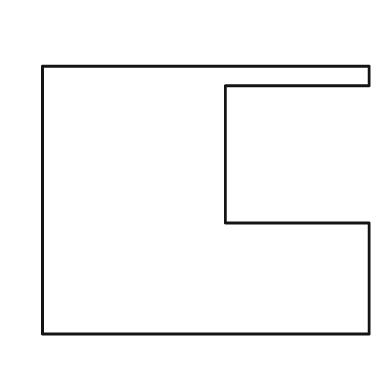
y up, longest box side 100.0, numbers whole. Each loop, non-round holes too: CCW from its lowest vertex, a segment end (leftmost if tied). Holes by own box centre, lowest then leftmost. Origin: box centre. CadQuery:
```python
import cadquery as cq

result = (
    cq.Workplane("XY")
    .moveTo(-50.0, -41.0)
    .lineTo(50.0, -41.0)
    .lineTo(50.0, -7.0)
    .lineTo(6.0, -7.0)
    .lineTo(6.0, 35.0)
    .lineTo(50.0, 35.0)
    .lineTo(50.0, 41.0)
    .lineTo(-50.0, 41.0)
    .close()
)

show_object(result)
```